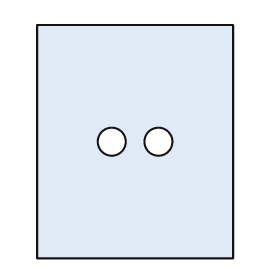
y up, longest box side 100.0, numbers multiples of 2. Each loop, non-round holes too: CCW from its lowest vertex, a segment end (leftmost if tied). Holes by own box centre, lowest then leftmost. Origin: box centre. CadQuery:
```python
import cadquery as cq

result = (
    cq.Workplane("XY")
    .moveTo(-42.0, -50.0)
    .lineTo(42.0, -50.0)
    .lineTo(42.0, 50.0)
    .lineTo(-42.0, 50.0)
    .close()
    .moveTo(-10.0, 0.0)
    .circle(6.0)
    .moveTo(10.0, 0.0)
    .circle(6.0)
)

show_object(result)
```